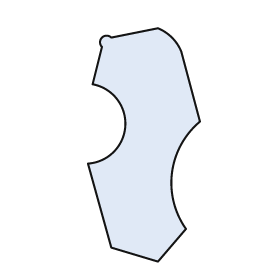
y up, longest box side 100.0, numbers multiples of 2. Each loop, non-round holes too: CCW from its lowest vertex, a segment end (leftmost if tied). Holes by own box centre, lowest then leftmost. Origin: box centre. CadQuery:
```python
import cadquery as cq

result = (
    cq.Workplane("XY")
    .moveTo(6.0, -50.0)
    .lineTo(18.0, -36.0)
    .threePointArc((12.0, -12.0), (24.0, 10.0))
    .lineTo(16.0, 40.0)
    .threePointArc((12.0, 46.0), (6.0, 50.0))
    .lineTo(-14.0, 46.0)
    .threePointArc((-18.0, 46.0), (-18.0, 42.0))
    .lineTo(-22.0, 26.0)
    .threePointArc((-8.0, 8.0), (-24.0, -8.0))
    .lineTo(-14.0, -44.0)
    .close()
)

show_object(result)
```